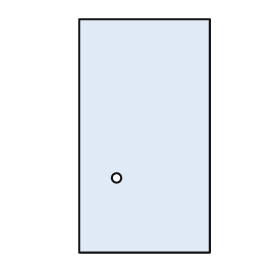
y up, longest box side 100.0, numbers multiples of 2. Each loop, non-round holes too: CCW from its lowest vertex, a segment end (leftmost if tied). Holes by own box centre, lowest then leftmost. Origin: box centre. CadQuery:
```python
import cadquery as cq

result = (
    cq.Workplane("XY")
    .moveTo(-28.0, -50.0)
    .lineTo(28.0, -50.0)
    .lineTo(28.0, 50.0)
    .lineTo(-28.0, 50.0)
    .close()
    .moveTo(-12.0, -18.0)
    .circle(2.0)
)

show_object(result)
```